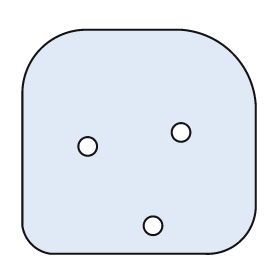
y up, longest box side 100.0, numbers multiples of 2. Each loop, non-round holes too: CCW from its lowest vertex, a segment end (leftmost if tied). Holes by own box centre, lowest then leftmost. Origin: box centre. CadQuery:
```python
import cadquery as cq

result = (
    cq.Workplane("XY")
    .moveTo(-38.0, -48.0)
    .lineTo(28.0, -48.0)
    .threePointArc((44.0, -42.0), (50.0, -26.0))
    .lineTo(50.0, 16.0)
    .threePointArc((40.0, 38.0), (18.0, 48.0))
    .lineTo(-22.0, 48.0)
    .threePointArc((-42.0, 40.0), (-50.0, 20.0))
    .lineTo(-50.0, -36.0)
    .threePointArc((-46.0, -44.0), (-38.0, -48.0))
    .close()
    .moveTo(6.0, -36.0)
    .circle(4.0)
    .moveTo(-22.0, -2.0)
    .circle(4.0)
    .moveTo(18.0, 4.0)
    .circle(4.0)
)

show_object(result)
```